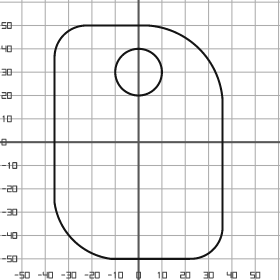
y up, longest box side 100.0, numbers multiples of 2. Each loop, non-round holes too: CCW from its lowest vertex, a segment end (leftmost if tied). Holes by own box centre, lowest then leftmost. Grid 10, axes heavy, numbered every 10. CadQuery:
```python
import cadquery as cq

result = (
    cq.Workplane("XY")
    .moveTo(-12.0, -50.0)
    .lineTo(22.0, -50.0)
    .threePointArc((32.0, -46.0), (36.0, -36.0))
    .lineTo(36.0, 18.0)
    .threePointArc((26.0, 40.0), (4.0, 50.0))
    .lineTo(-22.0, 50.0)
    .threePointArc((-32.0, 46.0), (-36.0, 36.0))
    .lineTo(-36.0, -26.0)
    .threePointArc((-28.0, -42.0), (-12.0, -50.0))
    .close()
    .moveTo(0.0, 30.0)
    .circle(10.0)
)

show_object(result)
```